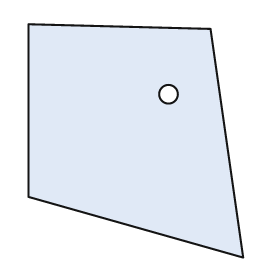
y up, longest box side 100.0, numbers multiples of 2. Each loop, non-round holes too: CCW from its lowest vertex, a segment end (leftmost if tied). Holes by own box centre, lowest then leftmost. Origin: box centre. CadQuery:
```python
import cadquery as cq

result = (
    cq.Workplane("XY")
    .moveTo(46.0, -50.0)
    .lineTo(32.0, 48.0)
    .lineTo(-46.0, 50.0)
    .lineTo(-46.0, -24.0)
    .close()
    .moveTo(14.0, 20.0)
    .circle(4.0)
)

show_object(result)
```